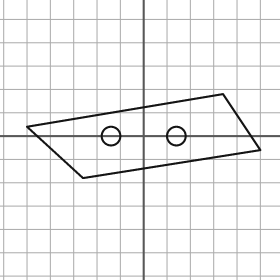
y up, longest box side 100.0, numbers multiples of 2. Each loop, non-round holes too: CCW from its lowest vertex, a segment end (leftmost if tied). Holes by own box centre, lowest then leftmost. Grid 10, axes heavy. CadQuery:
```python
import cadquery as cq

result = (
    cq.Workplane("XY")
    .moveTo(-26.0, -18.0)
    .lineTo(50.0, -6.0)
    .lineTo(34.0, 18.0)
    .lineTo(-50.0, 4.0)
    .close()
    .moveTo(-14.0, 0.0)
    .circle(4.0)
    .moveTo(14.0, 0.0)
    .circle(4.0)
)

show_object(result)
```